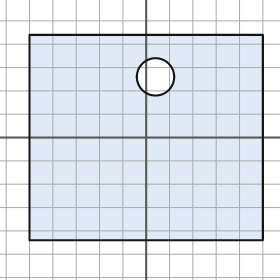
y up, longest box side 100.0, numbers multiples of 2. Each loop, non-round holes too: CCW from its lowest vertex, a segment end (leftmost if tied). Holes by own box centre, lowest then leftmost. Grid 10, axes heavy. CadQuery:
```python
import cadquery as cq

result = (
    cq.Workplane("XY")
    .moveTo(-50.0, -44.0)
    .lineTo(50.0, -44.0)
    .lineTo(50.0, 44.0)
    .lineTo(-50.0, 44.0)
    .close()
    .moveTo(4.0, 26.0)
    .circle(8.0)
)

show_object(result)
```